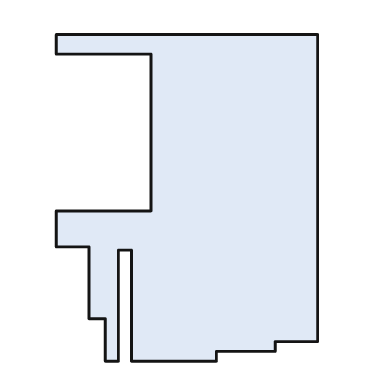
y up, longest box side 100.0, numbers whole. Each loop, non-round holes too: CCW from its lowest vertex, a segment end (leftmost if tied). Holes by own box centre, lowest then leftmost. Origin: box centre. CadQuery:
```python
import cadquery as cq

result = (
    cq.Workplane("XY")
    .moveTo(-25.0, -50.0)
    .lineTo(-21.0, -50.0)
    .lineTo(-21.0, -16.0)
    .lineTo(-17.0, -16.0)
    .lineTo(-17.0, -50.0)
    .lineTo(9.0, -50.0)
    .lineTo(9.0, -47.0)
    .lineTo(27.0, -47.0)
    .lineTo(27.0, -44.0)
    .lineTo(40.0, -44.0)
    .lineTo(40.0, 50.0)
    .lineTo(-40.0, 50.0)
    .lineTo(-40.0, 44.0)
    .lineTo(-11.0, 44.0)
    .lineTo(-11.0, -4.0)
    .lineTo(-40.0, -4.0)
    .lineTo(-40.0, -15.0)
    .lineTo(-30.0, -15.0)
    .lineTo(-30.0, -37.0)
    .lineTo(-25.0, -37.0)
    .close()
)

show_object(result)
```